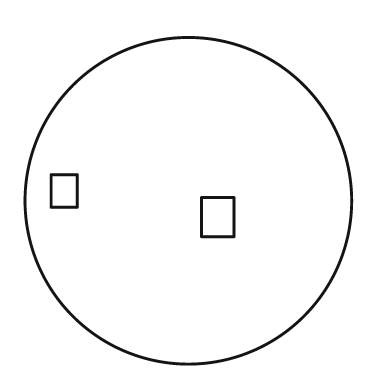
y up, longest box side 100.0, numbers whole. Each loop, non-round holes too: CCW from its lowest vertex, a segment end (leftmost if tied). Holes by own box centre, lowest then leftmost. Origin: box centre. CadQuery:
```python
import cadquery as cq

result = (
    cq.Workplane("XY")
    .moveTo(0.0, 0.0)
    .circle(50.0)
    .moveTo(4.0, -11.0)
    .lineTo(14.0, -11.0)
    .lineTo(14.0, 1.0)
    .lineTo(4.0, 1.0)
    .close()
    .moveTo(-42.0, -2.0)
    .lineTo(-34.0, -2.0)
    .lineTo(-34.0, 8.0)
    .lineTo(-42.0, 8.0)
    .close()
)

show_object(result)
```